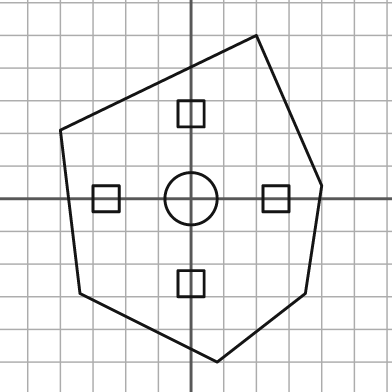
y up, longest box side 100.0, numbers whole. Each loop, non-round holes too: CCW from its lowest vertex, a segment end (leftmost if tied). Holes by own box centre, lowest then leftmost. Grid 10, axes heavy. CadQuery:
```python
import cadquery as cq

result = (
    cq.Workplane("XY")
    .moveTo(8.0, -50.0)
    .lineTo(35.0, -29.0)
    .lineTo(40.0, 4.0)
    .lineTo(20.0, 50.0)
    .lineTo(-40.0, 21.0)
    .lineTo(-34.0, -29.0)
    .close()
    .moveTo(-4.0, -30.0)
    .lineTo(4.0, -30.0)
    .lineTo(4.0, -22.0)
    .lineTo(-4.0, -22.0)
    .close()
    .moveTo(-30.0, -4.0)
    .lineTo(-22.0, -4.0)
    .lineTo(-22.0, 4.0)
    .lineTo(-30.0, 4.0)
    .close()
    .moveTo(0.0, 0.0)
    .circle(8.0)
    .moveTo(22.0, -4.0)
    .lineTo(30.0, -4.0)
    .lineTo(30.0, 4.0)
    .lineTo(22.0, 4.0)
    .close()
    .moveTo(-4.0, 22.0)
    .lineTo(4.0, 22.0)
    .lineTo(4.0, 30.0)
    .lineTo(-4.0, 30.0)
    .close()
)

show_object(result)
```